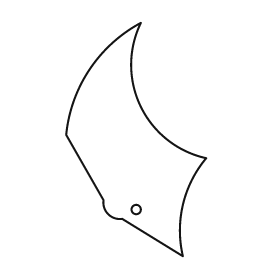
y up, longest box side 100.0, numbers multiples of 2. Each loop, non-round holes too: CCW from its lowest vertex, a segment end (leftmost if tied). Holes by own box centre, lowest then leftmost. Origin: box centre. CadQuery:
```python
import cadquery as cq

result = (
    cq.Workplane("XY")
    .moveTo(20.0, -50.0)
    .threePointArc((20.0, -28.0), (30.0, -8.0))
    .threePointArc((2.0, 14.0), (2.0, 50.0))
    .threePointArc((-20.0, 30.0), (-30.0, 2.0))
    .lineTo(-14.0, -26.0)
    .threePointArc((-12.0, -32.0), (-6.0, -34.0))
    .close()
    .moveTo(0.0, -30.0)
    .circle(2.0)
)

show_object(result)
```